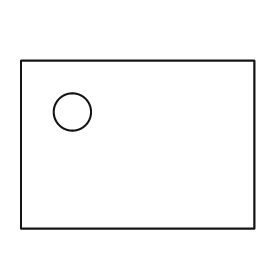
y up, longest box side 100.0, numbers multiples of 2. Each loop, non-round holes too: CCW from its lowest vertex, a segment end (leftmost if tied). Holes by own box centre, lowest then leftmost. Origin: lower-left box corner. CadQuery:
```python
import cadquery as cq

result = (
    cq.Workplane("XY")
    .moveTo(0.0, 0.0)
    .lineTo(100.0, 0.0)
    .lineTo(100.0, 72.0)
    .lineTo(0.0, 72.0)
    .close()
    .moveTo(22.0, 50.0)
    .circle(8.0)
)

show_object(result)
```